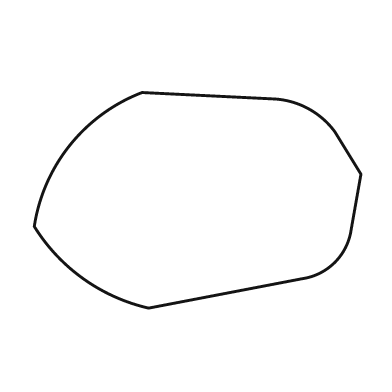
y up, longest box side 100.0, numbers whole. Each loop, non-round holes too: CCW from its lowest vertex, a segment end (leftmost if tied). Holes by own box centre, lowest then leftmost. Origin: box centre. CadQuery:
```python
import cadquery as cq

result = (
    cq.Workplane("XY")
    .moveTo(-15.0, -33.0)
    .lineTo(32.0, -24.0)
    .threePointArc((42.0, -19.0), (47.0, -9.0))
    .lineTo(50.0, 8.0)
    .lineTo(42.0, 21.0)
    .threePointArc((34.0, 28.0), (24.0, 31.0))
    .lineTo(-17.0, 33.0)
    .threePointArc((-39.0, 17.0), (-50.0, -8.0))
    .threePointArc((-35.0, -24.0), (-15.0, -33.0))
    .close()
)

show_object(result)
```